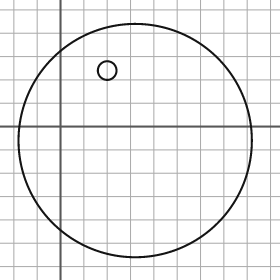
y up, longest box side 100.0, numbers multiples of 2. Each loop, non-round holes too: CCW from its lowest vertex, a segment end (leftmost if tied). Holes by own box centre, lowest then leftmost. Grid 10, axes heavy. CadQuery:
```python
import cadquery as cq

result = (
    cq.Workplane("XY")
    .moveTo(32.0, -6.0)
    .circle(50.0)
    .moveTo(20.0, 24.0)
    .circle(4.0)
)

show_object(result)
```